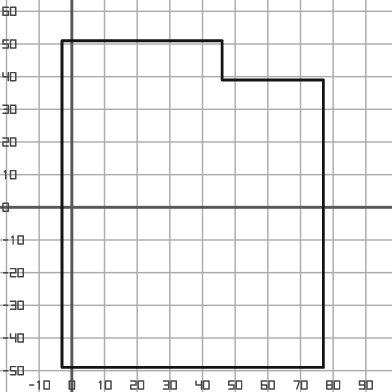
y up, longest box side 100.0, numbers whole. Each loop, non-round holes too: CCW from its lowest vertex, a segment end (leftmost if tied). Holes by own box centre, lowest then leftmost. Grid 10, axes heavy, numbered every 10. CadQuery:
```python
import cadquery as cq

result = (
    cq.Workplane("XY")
    .moveTo(-3.0, -49.0)
    .lineTo(77.0, -49.0)
    .lineTo(77.0, 39.0)
    .lineTo(46.0, 39.0)
    .lineTo(46.0, 51.0)
    .lineTo(-3.0, 51.0)
    .close()
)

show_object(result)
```